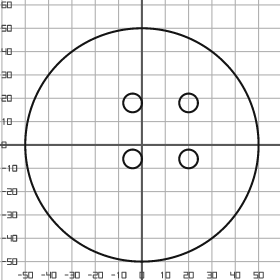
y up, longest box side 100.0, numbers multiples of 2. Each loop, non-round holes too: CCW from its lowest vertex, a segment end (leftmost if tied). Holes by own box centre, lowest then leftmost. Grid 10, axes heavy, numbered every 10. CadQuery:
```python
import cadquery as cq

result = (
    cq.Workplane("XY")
    .moveTo(0.0, 0.0)
    .circle(50.0)
    .moveTo(-4.0, -6.0)
    .circle(4.0)
    .moveTo(20.0, -6.0)
    .circle(4.0)
    .moveTo(-4.0, 18.0)
    .circle(4.0)
    .moveTo(20.0, 18.0)
    .circle(4.0)
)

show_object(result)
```